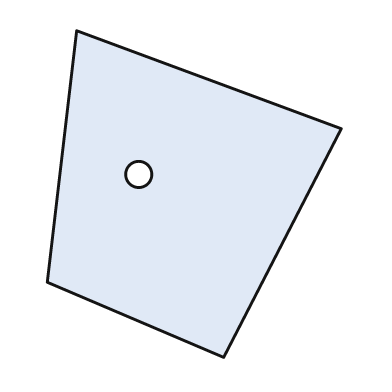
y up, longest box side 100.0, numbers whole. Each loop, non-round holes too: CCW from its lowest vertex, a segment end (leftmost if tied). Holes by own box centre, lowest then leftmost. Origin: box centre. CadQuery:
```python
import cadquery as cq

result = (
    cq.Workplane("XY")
    .moveTo(9.0, -50.0)
    .lineTo(45.0, 20.0)
    .lineTo(-36.0, 50.0)
    .lineTo(-45.0, -27.0)
    .close()
    .moveTo(-17.0, 6.0)
    .circle(4.0)
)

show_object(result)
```